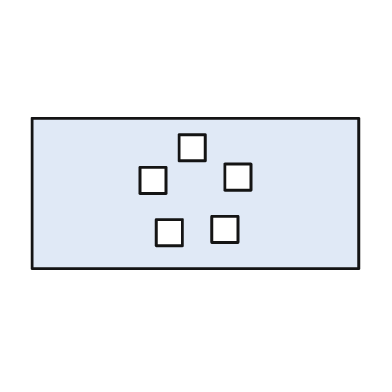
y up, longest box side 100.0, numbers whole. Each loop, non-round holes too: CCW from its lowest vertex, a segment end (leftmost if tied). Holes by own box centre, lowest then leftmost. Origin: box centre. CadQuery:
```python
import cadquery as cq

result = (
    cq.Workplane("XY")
    .moveTo(-50.0, -23.0)
    .lineTo(50.0, -23.0)
    .lineTo(50.0, 23.0)
    .lineTo(-50.0, 23.0)
    .close()
    .moveTo(-12.0, -16.0)
    .lineTo(-4.0, -16.0)
    .lineTo(-4.0, -8.0)
    .lineTo(-12.0, -8.0)
    .close()
    .moveTo(5.0, -15.0)
    .lineTo(13.0, -15.0)
    .lineTo(13.0, -7.0)
    .lineTo(5.0, -7.0)
    .close()
    .moveTo(-17.0, 0.0)
    .lineTo(-9.0, 0.0)
    .lineTo(-9.0, 8.0)
    .lineTo(-17.0, 8.0)
    .close()
    .moveTo(9.0, 1.0)
    .lineTo(17.0, 1.0)
    .lineTo(17.0, 9.0)
    .lineTo(9.0, 9.0)
    .close()
    .moveTo(-5.0, 10.0)
    .lineTo(3.0, 10.0)
    .lineTo(3.0, 18.0)
    .lineTo(-5.0, 18.0)
    .close()
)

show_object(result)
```